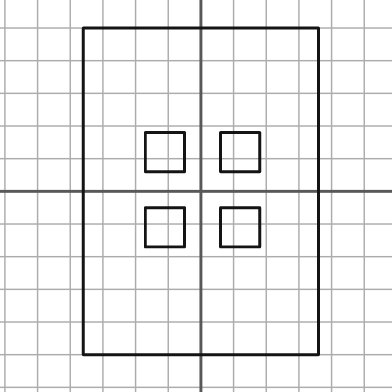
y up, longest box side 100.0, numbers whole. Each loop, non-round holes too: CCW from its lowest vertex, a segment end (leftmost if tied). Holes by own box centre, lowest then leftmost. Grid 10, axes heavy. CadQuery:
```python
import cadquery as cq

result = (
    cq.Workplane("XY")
    .moveTo(-36.0, -50.0)
    .lineTo(36.0, -50.0)
    .lineTo(36.0, 50.0)
    .lineTo(-36.0, 50.0)
    .close()
    .moveTo(-17.0, -17.0)
    .lineTo(-5.0, -17.0)
    .lineTo(-5.0, -5.0)
    .lineTo(-17.0, -5.0)
    .close()
    .moveTo(6.0, -17.0)
    .lineTo(18.0, -17.0)
    .lineTo(18.0, -5.0)
    .lineTo(6.0, -5.0)
    .close()
    .moveTo(-17.0, 6.0)
    .lineTo(-5.0, 6.0)
    .lineTo(-5.0, 18.0)
    .lineTo(-17.0, 18.0)
    .close()
    .moveTo(6.0, 6.0)
    .lineTo(18.0, 6.0)
    .lineTo(18.0, 18.0)
    .lineTo(6.0, 18.0)
    .close()
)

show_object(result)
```